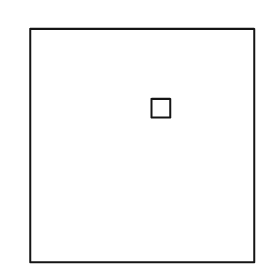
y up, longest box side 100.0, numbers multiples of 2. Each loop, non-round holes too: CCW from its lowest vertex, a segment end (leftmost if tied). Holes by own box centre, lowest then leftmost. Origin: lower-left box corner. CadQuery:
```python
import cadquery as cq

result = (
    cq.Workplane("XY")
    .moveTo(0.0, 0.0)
    .lineTo(96.0, 0.0)
    .lineTo(96.0, 100.0)
    .lineTo(0.0, 100.0)
    .close()
    .moveTo(52.0, 62.0)
    .lineTo(60.0, 62.0)
    .lineTo(60.0, 70.0)
    .lineTo(52.0, 70.0)
    .close()
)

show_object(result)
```